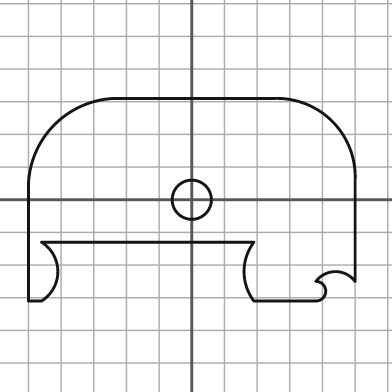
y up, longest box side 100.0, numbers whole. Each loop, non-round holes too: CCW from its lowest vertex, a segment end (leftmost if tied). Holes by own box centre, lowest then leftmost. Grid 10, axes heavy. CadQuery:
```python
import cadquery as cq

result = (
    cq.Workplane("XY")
    .moveTo(-50.0, -31.0)
    .lineTo(-46.0, -31.0)
    .threePointArc((-41.0, -22.0), (-46.0, -13.0))
    .lineTo(19.0, -13.0)
    .threePointArc((16.0, -22.0), (19.0, -31.0))
    .lineTo(38.0, -31.0)
    .threePointArc((41.0, -28.0), (38.0, -25.0))
    .threePointArc((44.0, -22.0), (50.0, -25.0))
    .lineTo(50.0, 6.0)
    .threePointArc((43.0, 24.0), (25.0, 31.0))
    .lineTo(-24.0, 31.0)
    .threePointArc((-42.0, 23.0), (-50.0, 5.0))
    .close()
    .moveTo(0.0, 0.0)
    .circle(6.0)
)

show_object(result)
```